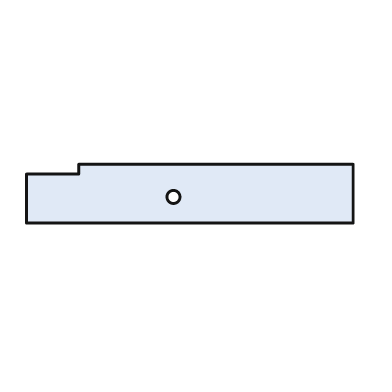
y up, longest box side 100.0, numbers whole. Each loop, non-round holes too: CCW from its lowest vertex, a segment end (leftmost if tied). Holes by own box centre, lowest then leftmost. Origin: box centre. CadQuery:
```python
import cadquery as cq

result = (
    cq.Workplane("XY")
    .moveTo(-50.0, -9.0)
    .lineTo(50.0, -9.0)
    .lineTo(50.0, 9.0)
    .lineTo(-34.0, 9.0)
    .lineTo(-34.0, 6.0)
    .lineTo(-50.0, 6.0)
    .close()
    .moveTo(-5.0, -1.0)
    .circle(2.0)
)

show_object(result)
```